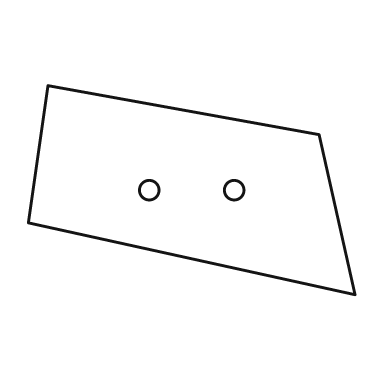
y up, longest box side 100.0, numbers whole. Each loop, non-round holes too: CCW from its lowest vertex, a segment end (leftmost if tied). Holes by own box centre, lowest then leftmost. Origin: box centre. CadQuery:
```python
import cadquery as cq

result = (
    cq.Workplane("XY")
    .moveTo(50.0, -32.0)
    .lineTo(39.0, 17.0)
    .lineTo(-44.0, 32.0)
    .lineTo(-50.0, -10.0)
    .close()
    .moveTo(-13.0, 0.0)
    .circle(3.0)
    .moveTo(13.0, 0.0)
    .circle(3.0)
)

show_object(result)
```